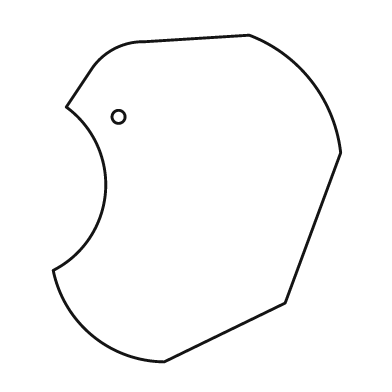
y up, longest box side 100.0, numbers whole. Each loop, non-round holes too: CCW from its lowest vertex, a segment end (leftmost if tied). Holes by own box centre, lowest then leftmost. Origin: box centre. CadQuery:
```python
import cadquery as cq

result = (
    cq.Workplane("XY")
    .moveTo(-10.0, -50.0)
    .lineTo(27.0, -32.0)
    .lineTo(44.0, 14.0)
    .threePointArc((35.0, 36.0), (16.0, 50.0))
    .lineTo(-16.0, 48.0)
    .threePointArc((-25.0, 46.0), (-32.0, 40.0))
    .lineTo(-40.0, 28.0)
    .threePointArc((-28.0, 2.0), (-44.0, -22.0))
    .threePointArc((-32.0, -42.0), (-10.0, -50.0))
    .close()
    .moveTo(-24.0, 25.0)
    .circle(2.0)
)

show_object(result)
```